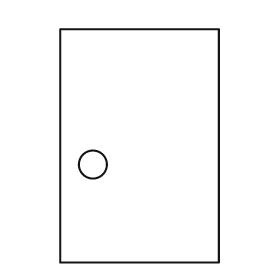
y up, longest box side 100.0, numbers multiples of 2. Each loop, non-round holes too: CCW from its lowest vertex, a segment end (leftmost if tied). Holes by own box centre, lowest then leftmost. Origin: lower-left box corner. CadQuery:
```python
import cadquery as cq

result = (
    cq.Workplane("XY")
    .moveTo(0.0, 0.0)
    .lineTo(68.0, 0.0)
    .lineTo(68.0, 100.0)
    .lineTo(0.0, 100.0)
    .close()
    .moveTo(14.0, 42.0)
    .circle(6.0)
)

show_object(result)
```